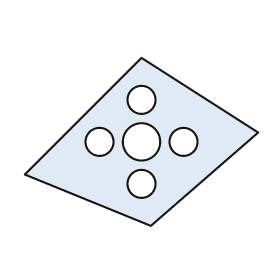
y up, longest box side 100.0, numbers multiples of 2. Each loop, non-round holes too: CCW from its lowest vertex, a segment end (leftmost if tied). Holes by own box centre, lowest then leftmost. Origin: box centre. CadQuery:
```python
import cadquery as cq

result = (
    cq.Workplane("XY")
    .moveTo(4.0, -36.0)
    .lineTo(50.0, 4.0)
    .lineTo(0.0, 36.0)
    .lineTo(-50.0, -14.0)
    .close()
    .moveTo(0.0, -18.0)
    .circle(6.0)
    .moveTo(-18.0, 0.0)
    .circle(6.0)
    .moveTo(0.0, 0.0)
    .circle(8.0)
    .moveTo(18.0, 0.0)
    .circle(6.0)
    .moveTo(0.0, 18.0)
    .circle(6.0)
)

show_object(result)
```